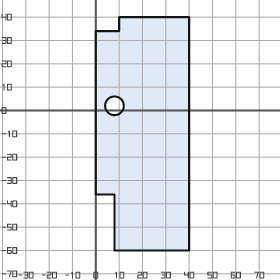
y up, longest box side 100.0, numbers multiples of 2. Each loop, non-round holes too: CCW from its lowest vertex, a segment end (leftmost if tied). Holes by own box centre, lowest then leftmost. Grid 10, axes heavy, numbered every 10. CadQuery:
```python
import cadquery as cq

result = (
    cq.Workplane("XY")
    .moveTo(8.0, -60.0)
    .lineTo(40.0, -60.0)
    .lineTo(40.0, 40.0)
    .lineTo(10.0, 40.0)
    .lineTo(10.0, 34.0)
    .lineTo(0.0, 34.0)
    .lineTo(0.0, -36.0)
    .lineTo(8.0, -36.0)
    .close()
    .moveTo(8.0, 2.0)
    .circle(4.0)
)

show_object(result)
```